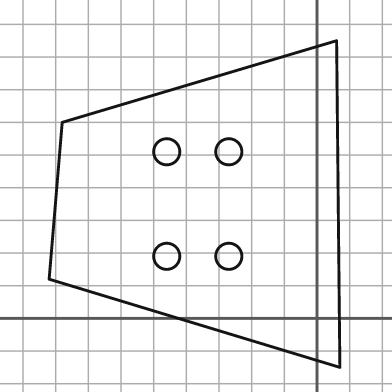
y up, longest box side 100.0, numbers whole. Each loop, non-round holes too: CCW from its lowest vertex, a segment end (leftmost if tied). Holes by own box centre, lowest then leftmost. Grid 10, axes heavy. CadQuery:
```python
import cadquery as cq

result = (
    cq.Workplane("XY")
    .moveTo(7.0, -15.0)
    .lineTo(6.0, 85.0)
    .lineTo(-78.0, 60.0)
    .lineTo(-82.0, 12.0)
    .close()
    .moveTo(-46.0, 19.0)
    .circle(4.0)
    .moveTo(-27.0, 19.0)
    .circle(4.0)
    .moveTo(-46.0, 51.0)
    .circle(4.0)
    .moveTo(-27.0, 51.0)
    .circle(4.0)
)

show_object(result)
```